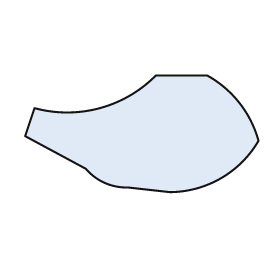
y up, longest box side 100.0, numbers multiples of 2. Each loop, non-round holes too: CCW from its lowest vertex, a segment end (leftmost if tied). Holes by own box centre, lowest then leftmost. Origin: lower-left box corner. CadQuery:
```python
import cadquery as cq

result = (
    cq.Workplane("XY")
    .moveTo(62.0, 0.0)
    .threePointArc((84.0, 6.0), (100.0, 22.0))
    .threePointArc((92.0, 38.0), (78.0, 50.0))
    .lineTo(56.0, 50.0)
    .threePointArc((32.0, 36.0), (4.0, 36.0))
    .lineTo(0.0, 24.0)
    .lineTo(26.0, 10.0)
    .threePointArc((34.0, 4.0), (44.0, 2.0))
    .close()
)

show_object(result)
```